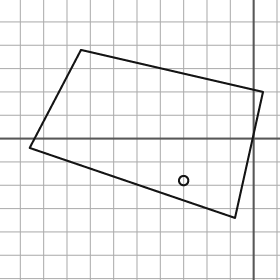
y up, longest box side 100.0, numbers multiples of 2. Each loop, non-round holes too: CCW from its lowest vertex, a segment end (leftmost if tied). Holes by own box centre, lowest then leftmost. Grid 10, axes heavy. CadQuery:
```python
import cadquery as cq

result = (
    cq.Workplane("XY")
    .moveTo(-8.0, -34.0)
    .lineTo(4.0, 20.0)
    .lineTo(-74.0, 38.0)
    .lineTo(-96.0, -4.0)
    .close()
    .moveTo(-30.0, -18.0)
    .circle(2.0)
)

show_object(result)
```